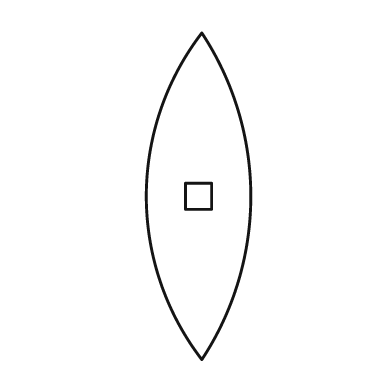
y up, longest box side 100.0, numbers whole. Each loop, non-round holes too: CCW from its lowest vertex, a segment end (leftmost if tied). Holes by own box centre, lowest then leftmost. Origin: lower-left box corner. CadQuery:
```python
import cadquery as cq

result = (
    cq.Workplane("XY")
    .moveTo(17.0, 0.0)
    .threePointArc((32.0, 50.0), (17.0, 100.0))
    .threePointArc((0.0, 50.0), (17.0, 0.0))
    .close()
    .moveTo(12.0, 46.0)
    .lineTo(20.0, 46.0)
    .lineTo(20.0, 54.0)
    .lineTo(12.0, 54.0)
    .close()
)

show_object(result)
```